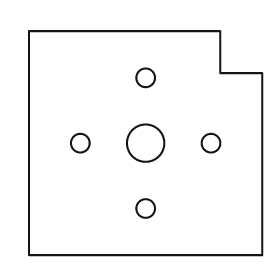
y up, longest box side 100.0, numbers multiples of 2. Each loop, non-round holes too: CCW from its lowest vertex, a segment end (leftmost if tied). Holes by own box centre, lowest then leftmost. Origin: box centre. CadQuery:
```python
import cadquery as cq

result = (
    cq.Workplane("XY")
    .moveTo(-50.0, -48.0)
    .lineTo(50.0, -48.0)
    .lineTo(50.0, 30.0)
    .lineTo(32.0, 30.0)
    .lineTo(32.0, 48.0)
    .lineTo(-50.0, 48.0)
    .close()
    .moveTo(0.0, -28.0)
    .circle(4.0)
    .moveTo(-28.0, 0.0)
    .circle(4.0)
    .moveTo(0.0, 0.0)
    .circle(8.0)
    .moveTo(28.0, 0.0)
    .circle(4.0)
    .moveTo(0.0, 28.0)
    .circle(4.0)
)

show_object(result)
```